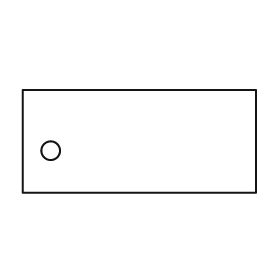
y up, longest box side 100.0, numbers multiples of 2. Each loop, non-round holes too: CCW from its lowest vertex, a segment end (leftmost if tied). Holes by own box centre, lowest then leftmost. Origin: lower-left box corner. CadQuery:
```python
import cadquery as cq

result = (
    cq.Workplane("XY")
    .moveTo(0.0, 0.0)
    .lineTo(100.0, 0.0)
    .lineTo(100.0, 44.0)
    .lineTo(0.0, 44.0)
    .close()
    .moveTo(12.0, 18.0)
    .circle(4.0)
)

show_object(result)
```